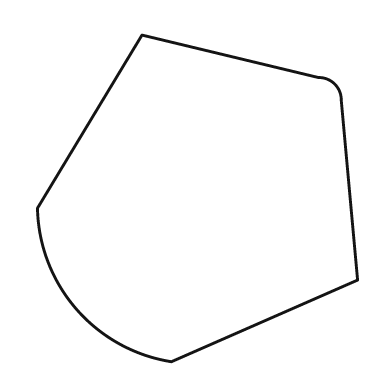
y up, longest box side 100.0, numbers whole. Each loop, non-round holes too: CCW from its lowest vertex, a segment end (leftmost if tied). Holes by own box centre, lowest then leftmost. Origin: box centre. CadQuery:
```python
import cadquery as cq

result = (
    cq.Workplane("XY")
    .moveTo(-8.0, -50.0)
    .lineTo(49.0, -25.0)
    .lineTo(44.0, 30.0)
    .threePointArc((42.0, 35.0), (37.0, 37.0))
    .lineTo(-17.0, 50.0)
    .lineTo(-49.0, -3.0)
    .threePointArc((-37.0, -34.0), (-8.0, -50.0))
    .close()
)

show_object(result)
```